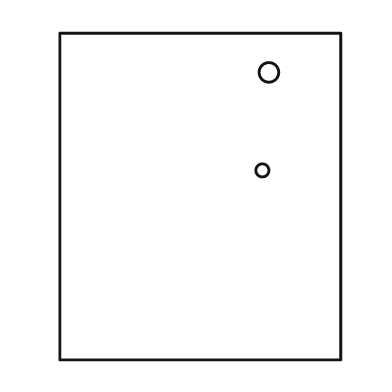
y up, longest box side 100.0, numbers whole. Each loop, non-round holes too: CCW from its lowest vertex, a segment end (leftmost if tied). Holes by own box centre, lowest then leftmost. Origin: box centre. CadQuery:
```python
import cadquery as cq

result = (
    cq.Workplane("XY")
    .moveTo(-43.0, -50.0)
    .lineTo(43.0, -50.0)
    .lineTo(43.0, 50.0)
    .lineTo(-43.0, 50.0)
    .close()
    .moveTo(19.0, 8.0)
    .circle(2.0)
    .moveTo(21.0, 38.0)
    .circle(3.0)
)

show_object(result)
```